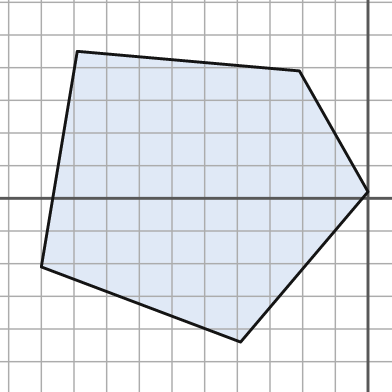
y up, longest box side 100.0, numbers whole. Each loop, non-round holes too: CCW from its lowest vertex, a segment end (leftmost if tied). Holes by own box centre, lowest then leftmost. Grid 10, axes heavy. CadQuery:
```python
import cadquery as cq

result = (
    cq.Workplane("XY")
    .moveTo(-39.0, -44.0)
    .lineTo(0.0, 2.0)
    .lineTo(-21.0, 39.0)
    .lineTo(-89.0, 45.0)
    .lineTo(-100.0, -21.0)
    .close()
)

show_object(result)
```